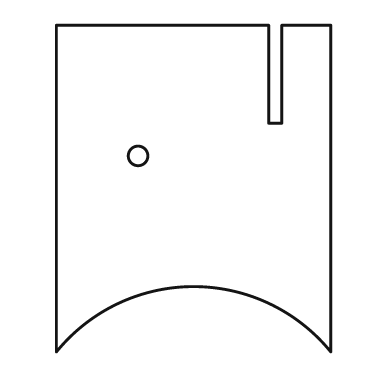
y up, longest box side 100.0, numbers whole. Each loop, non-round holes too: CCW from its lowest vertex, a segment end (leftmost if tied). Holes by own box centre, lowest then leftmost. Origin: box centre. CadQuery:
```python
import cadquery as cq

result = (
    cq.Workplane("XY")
    .moveTo(-42.0, -50.0)
    .threePointArc((0.0, -30.0), (42.0, -50.0))
    .lineTo(42.0, 50.0)
    .lineTo(27.0, 50.0)
    .lineTo(27.0, 20.0)
    .lineTo(23.0, 20.0)
    .lineTo(23.0, 50.0)
    .lineTo(-42.0, 50.0)
    .close()
    .moveTo(-17.0, 10.0)
    .circle(3.0)
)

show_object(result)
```